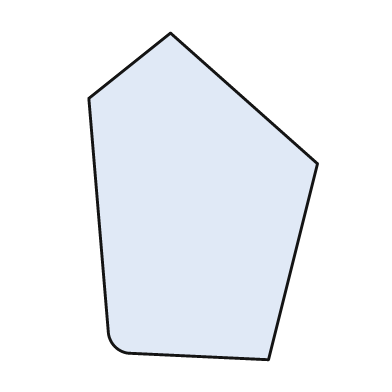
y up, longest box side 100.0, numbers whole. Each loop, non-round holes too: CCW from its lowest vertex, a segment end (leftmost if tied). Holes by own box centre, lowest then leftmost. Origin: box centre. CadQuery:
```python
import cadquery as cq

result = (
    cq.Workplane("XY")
    .moveTo(20.0, -50.0)
    .lineTo(35.0, 10.0)
    .lineTo(-10.0, 50.0)
    .lineTo(-35.0, 30.0)
    .lineTo(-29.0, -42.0)
    .threePointArc((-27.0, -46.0), (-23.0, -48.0))
    .close()
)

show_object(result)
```